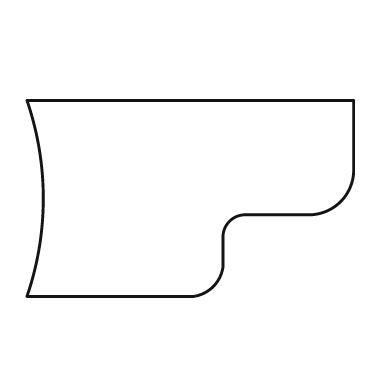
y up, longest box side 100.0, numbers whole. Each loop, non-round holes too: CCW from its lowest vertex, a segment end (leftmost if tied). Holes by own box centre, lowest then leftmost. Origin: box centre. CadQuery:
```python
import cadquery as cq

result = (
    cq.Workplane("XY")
    .moveTo(-50.0, -30.0)
    .lineTo(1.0, -30.0)
    .threePointArc((7.0, -27.0), (10.0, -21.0))
    .lineTo(10.0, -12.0)
    .threePointArc((12.0, -7.0), (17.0, -5.0))
    .lineTo(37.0, -5.0)
    .threePointArc((46.0, -1.0), (50.0, 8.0))
    .lineTo(50.0, 30.0)
    .lineTo(-50.0, 30.0)
    .threePointArc((-45.0, 0.0), (-50.0, -30.0))
    .close()
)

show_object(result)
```